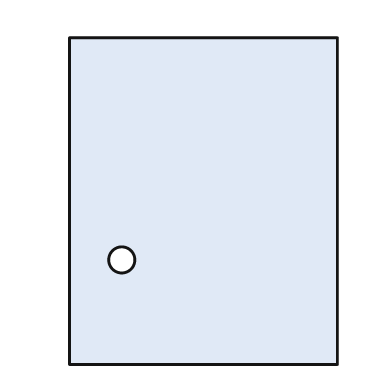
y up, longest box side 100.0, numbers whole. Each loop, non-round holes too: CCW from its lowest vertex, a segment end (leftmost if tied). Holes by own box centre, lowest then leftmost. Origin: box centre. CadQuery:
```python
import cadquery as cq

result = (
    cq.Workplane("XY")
    .moveTo(-41.0, -50.0)
    .lineTo(41.0, -50.0)
    .lineTo(41.0, 50.0)
    .lineTo(-41.0, 50.0)
    .close()
    .moveTo(-25.0, -18.0)
    .circle(4.0)
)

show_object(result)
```